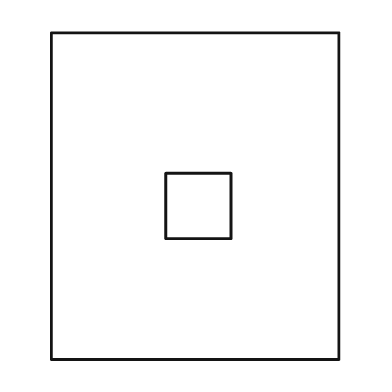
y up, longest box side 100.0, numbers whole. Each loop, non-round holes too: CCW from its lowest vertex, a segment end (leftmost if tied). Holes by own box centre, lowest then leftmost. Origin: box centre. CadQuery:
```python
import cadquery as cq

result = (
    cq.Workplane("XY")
    .moveTo(-44.0, -50.0)
    .lineTo(44.0, -50.0)
    .lineTo(44.0, 50.0)
    .lineTo(-44.0, 50.0)
    .close()
    .moveTo(-9.0, -13.0)
    .lineTo(11.0, -13.0)
    .lineTo(11.0, 7.0)
    .lineTo(-9.0, 7.0)
    .close()
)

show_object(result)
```